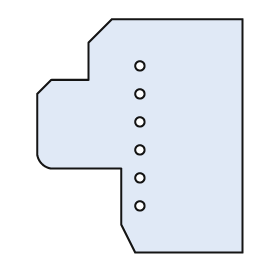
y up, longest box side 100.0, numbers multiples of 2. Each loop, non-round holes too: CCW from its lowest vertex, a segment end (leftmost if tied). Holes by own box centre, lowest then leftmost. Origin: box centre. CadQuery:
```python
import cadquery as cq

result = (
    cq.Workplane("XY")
    .moveTo(-2.0, -50.0)
    .lineTo(44.0, -50.0)
    .lineTo(44.0, 50.0)
    .lineTo(-12.0, 50.0)
    .lineTo(-22.0, 40.0)
    .lineTo(-22.0, 24.0)
    .lineTo(-38.0, 24.0)
    .lineTo(-44.0, 18.0)
    .lineTo(-44.0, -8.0)
    .threePointArc((-42.0, -12.0), (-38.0, -14.0))
    .lineTo(-8.0, -14.0)
    .lineTo(-8.0, -38.0)
    .close()
    .moveTo(0.0, -30.0)
    .circle(2.0)
    .moveTo(0.0, -18.0)
    .circle(2.0)
    .moveTo(0.0, -6.0)
    .circle(2.0)
    .moveTo(0.0, 6.0)
    .circle(2.0)
    .moveTo(0.0, 18.0)
    .circle(2.0)
    .moveTo(0.0, 30.0)
    .circle(2.0)
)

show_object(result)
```